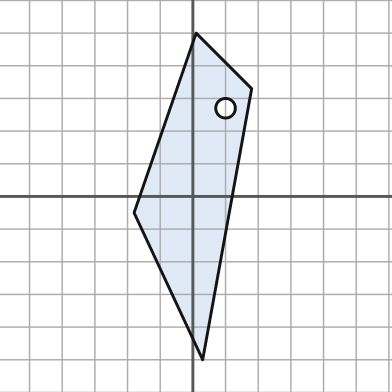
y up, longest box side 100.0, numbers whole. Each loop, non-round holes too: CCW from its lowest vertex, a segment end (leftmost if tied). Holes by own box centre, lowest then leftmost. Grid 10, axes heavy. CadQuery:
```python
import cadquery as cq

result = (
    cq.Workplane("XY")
    .moveTo(3.0, -50.0)
    .lineTo(18.0, 33.0)
    .lineTo(1.0, 50.0)
    .lineTo(-18.0, -5.0)
    .close()
    .moveTo(10.0, 27.0)
    .circle(3.0)
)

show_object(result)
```